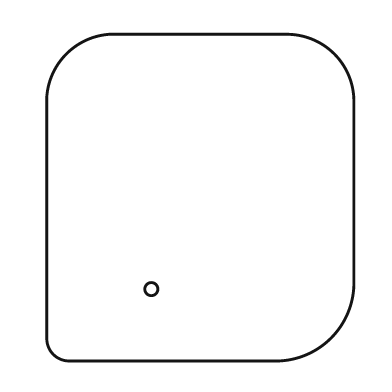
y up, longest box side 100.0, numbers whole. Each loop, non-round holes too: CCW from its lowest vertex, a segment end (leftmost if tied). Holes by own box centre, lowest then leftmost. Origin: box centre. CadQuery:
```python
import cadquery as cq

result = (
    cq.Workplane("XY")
    .moveTo(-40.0, -50.0)
    .lineTo(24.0, -50.0)
    .threePointArc((40.0, -43.0), (47.0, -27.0))
    .lineTo(47.0, 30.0)
    .threePointArc((41.0, 44.0), (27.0, 50.0))
    .lineTo(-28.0, 50.0)
    .threePointArc((-41.0, 44.0), (-47.0, 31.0))
    .lineTo(-47.0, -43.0)
    .threePointArc((-45.0, -48.0), (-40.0, -50.0))
    .close()
    .moveTo(-15.0, -28.0)
    .circle(2.0)
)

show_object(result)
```